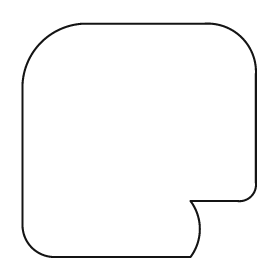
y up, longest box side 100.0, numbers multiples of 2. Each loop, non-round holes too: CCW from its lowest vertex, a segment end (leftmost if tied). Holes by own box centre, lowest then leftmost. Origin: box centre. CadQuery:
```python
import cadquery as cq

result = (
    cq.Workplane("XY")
    .moveTo(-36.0, -50.0)
    .lineTo(22.0, -50.0)
    .threePointArc((26.0, -38.0), (22.0, -26.0))
    .lineTo(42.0, -26.0)
    .threePointArc((48.0, -24.0), (50.0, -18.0))
    .lineTo(50.0, 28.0)
    .threePointArc((44.0, 44.0), (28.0, 50.0))
    .lineTo(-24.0, 50.0)
    .threePointArc((-42.0, 42.0), (-50.0, 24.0))
    .lineTo(-50.0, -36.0)
    .threePointArc((-46.0, -46.0), (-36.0, -50.0))
    .close()
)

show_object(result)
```